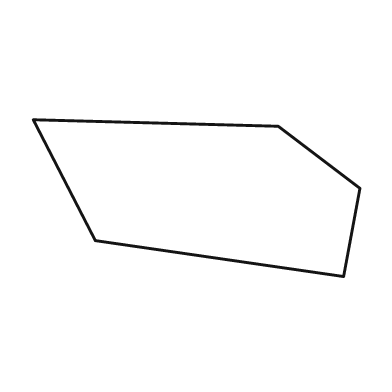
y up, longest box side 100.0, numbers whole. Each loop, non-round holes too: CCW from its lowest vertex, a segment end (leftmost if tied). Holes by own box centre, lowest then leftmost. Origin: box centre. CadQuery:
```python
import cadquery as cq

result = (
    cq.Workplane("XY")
    .moveTo(45.0, -24.0)
    .lineTo(50.0, 3.0)
    .lineTo(25.0, 22.0)
    .lineTo(-50.0, 24.0)
    .lineTo(-31.0, -13.0)
    .close()
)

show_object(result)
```